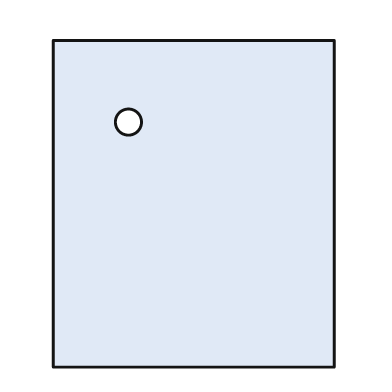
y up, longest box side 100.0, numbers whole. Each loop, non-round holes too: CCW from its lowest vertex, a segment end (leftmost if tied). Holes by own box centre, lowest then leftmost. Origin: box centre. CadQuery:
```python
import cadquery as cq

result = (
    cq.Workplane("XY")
    .moveTo(-43.0, -50.0)
    .lineTo(43.0, -50.0)
    .lineTo(43.0, 50.0)
    .lineTo(-43.0, 50.0)
    .close()
    .moveTo(-20.0, 25.0)
    .circle(4.0)
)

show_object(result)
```